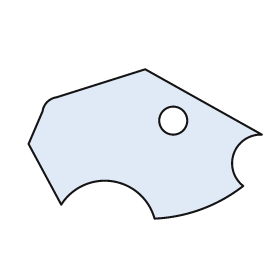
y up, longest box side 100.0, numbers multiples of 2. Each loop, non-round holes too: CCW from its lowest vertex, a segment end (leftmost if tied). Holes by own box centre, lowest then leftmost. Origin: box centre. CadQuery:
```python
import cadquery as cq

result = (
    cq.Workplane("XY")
    .moveTo(4.0, -32.0)
    .threePointArc((24.0, -28.0), (42.0, -18.0))
    .threePointArc((38.0, -4.0), (50.0, 4.0))
    .lineTo(0.0, 32.0)
    .lineTo(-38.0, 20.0)
    .threePointArc((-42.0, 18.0), (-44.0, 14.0))
    .lineTo(-50.0, 0.0)
    .lineTo(-36.0, -26.0)
    .threePointArc((-14.0, -16.0), (4.0, -32.0))
    .close()
    .moveTo(12.0, 10.0)
    .circle(6.0)
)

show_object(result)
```